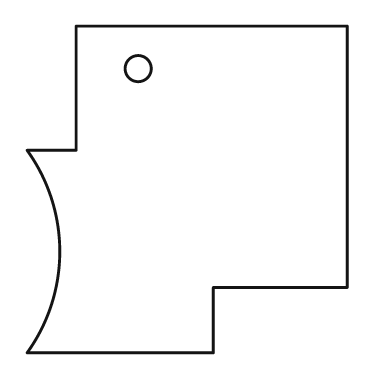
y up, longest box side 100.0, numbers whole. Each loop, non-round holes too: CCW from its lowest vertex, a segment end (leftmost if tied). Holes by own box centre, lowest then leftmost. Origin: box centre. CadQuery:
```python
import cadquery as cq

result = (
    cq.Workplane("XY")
    .moveTo(-49.0, -50.0)
    .lineTo(8.0, -50.0)
    .lineTo(8.0, -30.0)
    .lineTo(49.0, -30.0)
    .lineTo(49.0, 50.0)
    .lineTo(-34.0, 50.0)
    .lineTo(-34.0, 12.0)
    .lineTo(-49.0, 12.0)
    .threePointArc((-39.0, -19.0), (-49.0, -50.0))
    .close()
    .moveTo(-15.0, 37.0)
    .circle(4.0)
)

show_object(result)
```